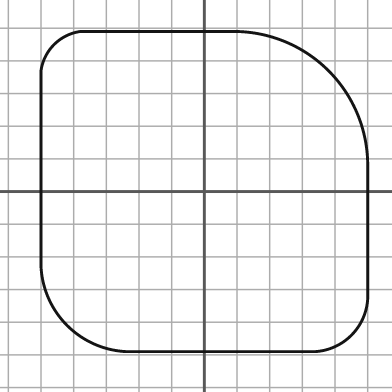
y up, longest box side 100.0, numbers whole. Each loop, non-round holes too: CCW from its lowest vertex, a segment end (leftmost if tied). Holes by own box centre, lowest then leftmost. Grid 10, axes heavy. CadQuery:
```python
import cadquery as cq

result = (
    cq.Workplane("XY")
    .moveTo(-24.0, -49.0)
    .lineTo(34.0, -49.0)
    .threePointArc((45.0, -44.0), (50.0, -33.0))
    .lineTo(50.0, 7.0)
    .threePointArc((38.0, 37.0), (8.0, 49.0))
    .lineTo(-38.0, 49.0)
    .threePointArc((-46.0, 45.0), (-50.0, 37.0))
    .lineTo(-50.0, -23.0)
    .threePointArc((-42.0, -41.0), (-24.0, -49.0))
    .close()
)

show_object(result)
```